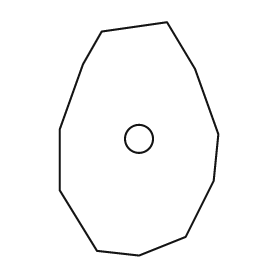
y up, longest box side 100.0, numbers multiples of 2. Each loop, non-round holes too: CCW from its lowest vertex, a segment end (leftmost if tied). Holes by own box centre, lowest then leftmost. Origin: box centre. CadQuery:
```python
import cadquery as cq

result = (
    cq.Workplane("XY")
    .moveTo(0.0, -50.0)
    .lineTo(20.0, -42.0)
    .lineTo(32.0, -18.0)
    .lineTo(34.0, 2.0)
    .lineTo(24.0, 30.0)
    .lineTo(12.0, 50.0)
    .lineTo(-16.0, 46.0)
    .lineTo(-24.0, 32.0)
    .lineTo(-34.0, 4.0)
    .lineTo(-34.0, -22.0)
    .lineTo(-18.0, -48.0)
    .close()
    .moveTo(0.0, 0.0)
    .circle(6.0)
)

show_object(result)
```